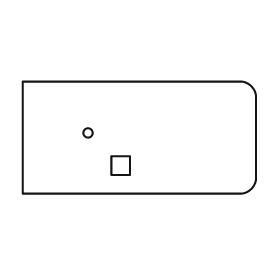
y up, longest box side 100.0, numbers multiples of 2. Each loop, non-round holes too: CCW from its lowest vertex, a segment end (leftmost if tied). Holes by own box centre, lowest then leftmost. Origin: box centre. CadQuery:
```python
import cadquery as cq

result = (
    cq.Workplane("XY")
    .moveTo(-50.0, -24.0)
    .lineTo(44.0, -24.0)
    .threePointArc((48.0, -22.0), (50.0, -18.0))
    .lineTo(50.0, 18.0)
    .threePointArc((48.0, 22.0), (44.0, 24.0))
    .lineTo(-50.0, 24.0)
    .close()
    .moveTo(-12.0, -16.0)
    .lineTo(-4.0, -16.0)
    .lineTo(-4.0, -8.0)
    .lineTo(-12.0, -8.0)
    .close()
    .moveTo(-22.0, 2.0)
    .circle(2.0)
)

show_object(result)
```